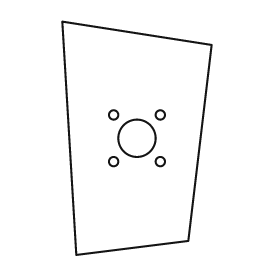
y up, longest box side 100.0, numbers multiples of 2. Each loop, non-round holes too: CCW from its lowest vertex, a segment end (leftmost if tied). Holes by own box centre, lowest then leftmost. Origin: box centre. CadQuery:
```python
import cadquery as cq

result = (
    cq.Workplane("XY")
    .moveTo(-26.0, -50.0)
    .lineTo(22.0, -44.0)
    .lineTo(32.0, 40.0)
    .lineTo(-32.0, 50.0)
    .close()
    .moveTo(-10.0, -10.0)
    .circle(2.0)
    .moveTo(10.0, -10.0)
    .circle(2.0)
    .moveTo(0.0, 0.0)
    .circle(8.0)
    .moveTo(-10.0, 10.0)
    .circle(2.0)
    .moveTo(10.0, 10.0)
    .circle(2.0)
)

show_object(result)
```